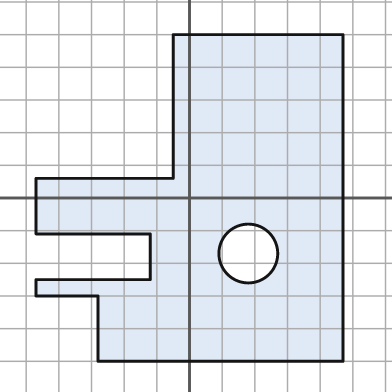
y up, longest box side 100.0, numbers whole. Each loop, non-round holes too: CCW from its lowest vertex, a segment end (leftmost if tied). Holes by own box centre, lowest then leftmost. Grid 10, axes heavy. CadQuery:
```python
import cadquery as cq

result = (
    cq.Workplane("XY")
    .moveTo(-28.0, -50.0)
    .lineTo(47.0, -50.0)
    .lineTo(47.0, 50.0)
    .lineTo(-5.0, 50.0)
    .lineTo(-5.0, 6.0)
    .lineTo(-47.0, 6.0)
    .lineTo(-47.0, -11.0)
    .lineTo(-12.0, -11.0)
    .lineTo(-12.0, -25.0)
    .lineTo(-47.0, -25.0)
    .lineTo(-47.0, -30.0)
    .lineTo(-28.0, -30.0)
    .close()
    .moveTo(18.0, -17.0)
    .circle(9.0)
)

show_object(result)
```